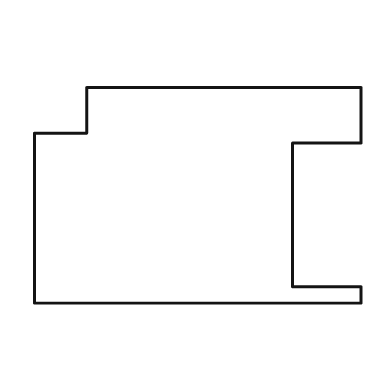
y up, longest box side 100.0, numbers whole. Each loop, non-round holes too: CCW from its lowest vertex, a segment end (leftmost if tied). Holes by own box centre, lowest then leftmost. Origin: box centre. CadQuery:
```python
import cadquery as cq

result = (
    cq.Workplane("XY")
    .moveTo(-50.0, -33.0)
    .lineTo(50.0, -33.0)
    .lineTo(50.0, -28.0)
    .lineTo(29.0, -28.0)
    .lineTo(29.0, 16.0)
    .lineTo(50.0, 16.0)
    .lineTo(50.0, 33.0)
    .lineTo(-34.0, 33.0)
    .lineTo(-34.0, 19.0)
    .lineTo(-50.0, 19.0)
    .close()
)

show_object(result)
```